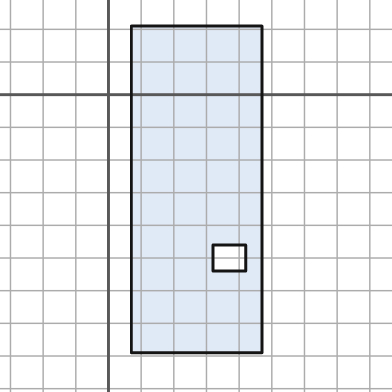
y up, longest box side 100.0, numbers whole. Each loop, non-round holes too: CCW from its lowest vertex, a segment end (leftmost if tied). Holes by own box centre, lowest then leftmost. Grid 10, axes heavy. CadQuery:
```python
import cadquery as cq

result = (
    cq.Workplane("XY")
    .moveTo(7.0, -79.0)
    .lineTo(47.0, -79.0)
    .lineTo(47.0, 21.0)
    .lineTo(7.0, 21.0)
    .close()
    .moveTo(32.0, -54.0)
    .lineTo(42.0, -54.0)
    .lineTo(42.0, -46.0)
    .lineTo(32.0, -46.0)
    .close()
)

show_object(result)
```